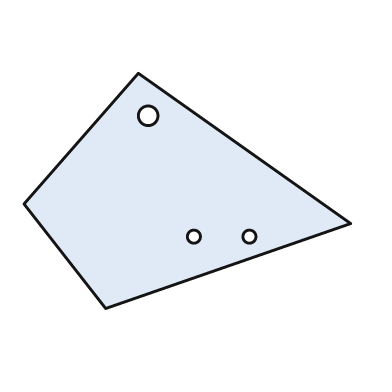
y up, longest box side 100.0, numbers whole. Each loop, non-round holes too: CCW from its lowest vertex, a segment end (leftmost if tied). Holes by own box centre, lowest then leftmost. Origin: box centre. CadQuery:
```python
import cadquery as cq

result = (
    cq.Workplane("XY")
    .moveTo(-25.0, -36.0)
    .lineTo(50.0, -10.0)
    .lineTo(-15.0, 36.0)
    .lineTo(-50.0, -4.0)
    .close()
    .moveTo(2.0, -14.0)
    .circle(2.0)
    .moveTo(19.0, -14.0)
    .circle(2.0)
    .moveTo(-12.0, 23.0)
    .circle(3.0)
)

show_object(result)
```